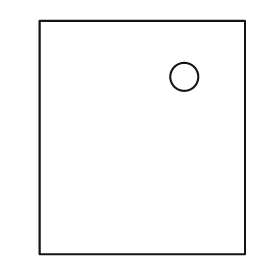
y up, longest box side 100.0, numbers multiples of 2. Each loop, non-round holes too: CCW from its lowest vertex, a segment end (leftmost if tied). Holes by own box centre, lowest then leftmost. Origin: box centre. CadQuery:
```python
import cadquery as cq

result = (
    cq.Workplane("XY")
    .moveTo(-44.0, -50.0)
    .lineTo(44.0, -50.0)
    .lineTo(44.0, 50.0)
    .lineTo(-44.0, 50.0)
    .close()
    .moveTo(18.0, 26.0)
    .circle(6.0)
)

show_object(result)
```